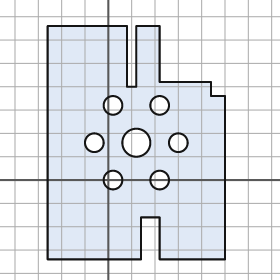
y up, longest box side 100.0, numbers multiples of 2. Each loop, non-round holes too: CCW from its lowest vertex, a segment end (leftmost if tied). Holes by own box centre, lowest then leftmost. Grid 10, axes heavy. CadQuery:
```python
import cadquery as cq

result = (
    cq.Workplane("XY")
    .moveTo(-26.0, -34.0)
    .lineTo(14.0, -34.0)
    .lineTo(14.0, -16.0)
    .lineTo(22.0, -16.0)
    .lineTo(22.0, -34.0)
    .lineTo(50.0, -34.0)
    .lineTo(50.0, 36.0)
    .lineTo(44.0, 36.0)
    .lineTo(44.0, 42.0)
    .lineTo(22.0, 42.0)
    .lineTo(22.0, 66.0)
    .lineTo(12.0, 66.0)
    .lineTo(12.0, 40.0)
    .lineTo(8.0, 40.0)
    .lineTo(8.0, 66.0)
    .lineTo(-26.0, 66.0)
    .close()
    .moveTo(2.0, 0.0)
    .circle(4.0)
    .moveTo(22.0, 0.0)
    .circle(4.0)
    .moveTo(-6.0, 16.0)
    .circle(4.0)
    .moveTo(12.0, 16.0)
    .circle(6.0)
    .moveTo(30.0, 16.0)
    .circle(4.0)
    .moveTo(2.0, 32.0)
    .circle(4.0)
    .moveTo(22.0, 32.0)
    .circle(4.0)
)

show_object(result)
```